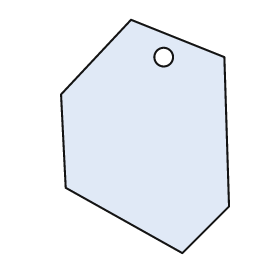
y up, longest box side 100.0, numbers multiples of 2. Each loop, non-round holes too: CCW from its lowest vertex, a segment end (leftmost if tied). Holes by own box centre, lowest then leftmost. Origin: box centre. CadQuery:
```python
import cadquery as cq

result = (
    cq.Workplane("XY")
    .moveTo(16.0, -50.0)
    .lineTo(36.0, -30.0)
    .lineTo(34.0, 34.0)
    .lineTo(-6.0, 50.0)
    .lineTo(-36.0, 18.0)
    .lineTo(-34.0, -22.0)
    .close()
    .moveTo(8.0, 34.0)
    .circle(4.0)
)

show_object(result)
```